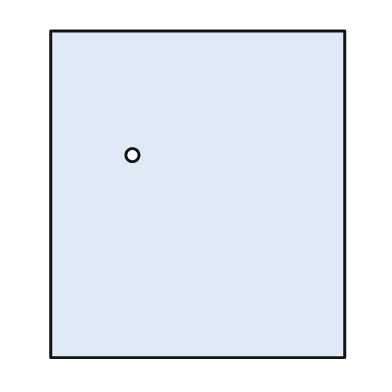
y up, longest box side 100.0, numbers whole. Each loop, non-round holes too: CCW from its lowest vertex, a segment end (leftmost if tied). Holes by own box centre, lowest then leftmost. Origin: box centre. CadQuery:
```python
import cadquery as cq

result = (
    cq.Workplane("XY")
    .moveTo(-45.0, -50.0)
    .lineTo(45.0, -50.0)
    .lineTo(45.0, 50.0)
    .lineTo(-45.0, 50.0)
    .close()
    .moveTo(-20.0, 12.0)
    .circle(2.0)
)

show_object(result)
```